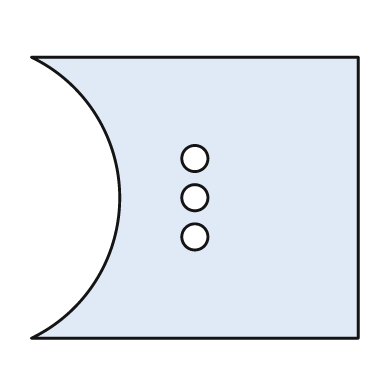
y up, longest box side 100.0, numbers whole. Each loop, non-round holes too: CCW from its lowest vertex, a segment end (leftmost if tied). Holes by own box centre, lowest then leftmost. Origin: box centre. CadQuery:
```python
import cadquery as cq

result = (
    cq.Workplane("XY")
    .moveTo(-50.0, -43.0)
    .lineTo(50.0, -43.0)
    .lineTo(50.0, 43.0)
    .lineTo(-50.0, 43.0)
    .threePointArc((-23.0, 0.0), (-50.0, -43.0))
    .close()
    .moveTo(0.0, -12.0)
    .circle(4.0)
    .moveTo(0.0, 0.0)
    .circle(4.0)
    .moveTo(0.0, 12.0)
    .circle(4.0)
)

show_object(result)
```